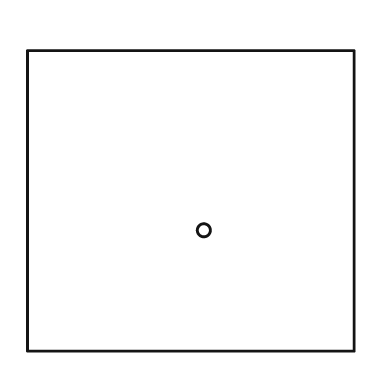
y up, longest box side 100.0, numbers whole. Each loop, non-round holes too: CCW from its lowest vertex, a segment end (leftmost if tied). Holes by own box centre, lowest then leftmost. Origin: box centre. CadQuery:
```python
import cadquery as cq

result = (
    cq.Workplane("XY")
    .moveTo(-50.0, -46.0)
    .lineTo(50.0, -46.0)
    .lineTo(50.0, 46.0)
    .lineTo(-50.0, 46.0)
    .close()
    .moveTo(4.0, -9.0)
    .circle(2.0)
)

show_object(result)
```